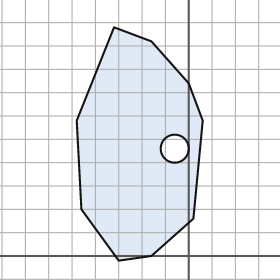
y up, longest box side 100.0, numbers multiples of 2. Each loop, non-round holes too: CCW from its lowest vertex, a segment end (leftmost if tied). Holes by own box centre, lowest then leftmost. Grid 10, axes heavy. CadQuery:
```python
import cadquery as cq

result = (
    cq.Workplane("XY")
    .moveTo(-30.0, -2.0)
    .lineTo(-16.0, 0.0)
    .lineTo(2.0, 16.0)
    .lineTo(6.0, 58.0)
    .lineTo(0.0, 74.0)
    .lineTo(-16.0, 92.0)
    .lineTo(-32.0, 98.0)
    .lineTo(-48.0, 58.0)
    .lineTo(-46.0, 20.0)
    .close()
    .moveTo(-6.0, 46.0)
    .circle(6.0)
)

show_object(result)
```